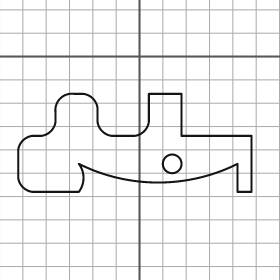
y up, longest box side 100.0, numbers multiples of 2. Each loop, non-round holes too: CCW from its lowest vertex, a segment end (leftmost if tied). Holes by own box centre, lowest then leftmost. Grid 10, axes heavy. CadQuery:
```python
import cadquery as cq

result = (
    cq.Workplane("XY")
    .moveTo(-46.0, -58.0)
    .lineTo(-26.0, -58.0)
    .threePointArc((-24.0, -52.0), (-26.0, -46.0))
    .threePointArc((8.0, -54.0), (42.0, -46.0))
    .lineTo(42.0, -58.0)
    .lineTo(48.0, -58.0)
    .lineTo(48.0, -34.0)
    .lineTo(18.0, -34.0)
    .lineTo(18.0, -16.0)
    .lineTo(4.0, -16.0)
    .lineTo(4.0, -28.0)
    .threePointArc((2.0, -32.0), (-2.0, -34.0))
    .lineTo(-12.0, -34.0)
    .threePointArc((-16.0, -32.0), (-18.0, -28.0))
    .lineTo(-18.0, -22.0)
    .threePointArc((-20.0, -18.0), (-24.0, -16.0))
    .lineTo(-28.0, -16.0)
    .threePointArc((-34.0, -18.0), (-36.0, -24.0))
    .lineTo(-36.0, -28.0)
    .threePointArc((-38.0, -32.0), (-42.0, -34.0))
    .lineTo(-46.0, -34.0)
    .threePointArc((-50.0, -36.0), (-52.0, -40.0))
    .lineTo(-52.0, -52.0)
    .threePointArc((-50.0, -56.0), (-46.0, -58.0))
    .close()
    .moveTo(14.0, -46.0)
    .circle(4.0)
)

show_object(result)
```